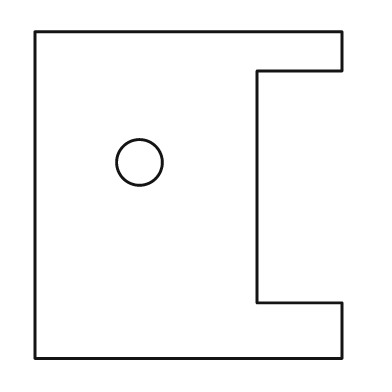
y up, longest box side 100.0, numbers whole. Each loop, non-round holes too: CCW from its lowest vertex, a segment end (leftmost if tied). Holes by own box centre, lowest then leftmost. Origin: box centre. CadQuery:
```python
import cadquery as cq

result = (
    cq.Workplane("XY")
    .moveTo(-47.0, -50.0)
    .lineTo(47.0, -50.0)
    .lineTo(47.0, -33.0)
    .lineTo(21.0, -33.0)
    .lineTo(21.0, 38.0)
    .lineTo(47.0, 38.0)
    .lineTo(47.0, 50.0)
    .lineTo(-47.0, 50.0)
    .close()
    .moveTo(-15.0, 10.0)
    .circle(7.0)
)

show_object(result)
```